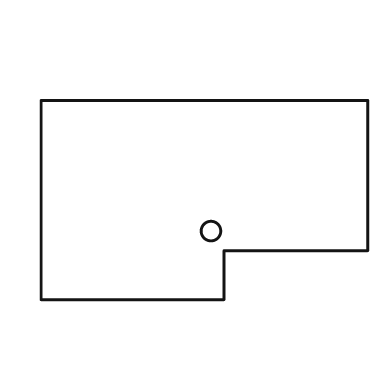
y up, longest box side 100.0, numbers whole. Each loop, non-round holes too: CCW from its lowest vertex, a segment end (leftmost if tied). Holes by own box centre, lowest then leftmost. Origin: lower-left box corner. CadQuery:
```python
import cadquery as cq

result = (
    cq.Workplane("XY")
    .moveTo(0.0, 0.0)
    .lineTo(56.0, 0.0)
    .lineTo(56.0, 15.0)
    .lineTo(100.0, 15.0)
    .lineTo(100.0, 61.0)
    .lineTo(0.0, 61.0)
    .close()
    .moveTo(52.0, 21.0)
    .circle(3.0)
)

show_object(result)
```